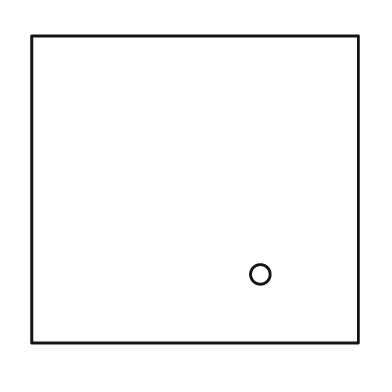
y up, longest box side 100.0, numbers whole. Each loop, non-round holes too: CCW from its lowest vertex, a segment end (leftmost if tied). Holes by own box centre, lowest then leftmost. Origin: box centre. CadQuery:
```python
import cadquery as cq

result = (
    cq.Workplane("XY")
    .moveTo(-50.0, -47.0)
    .lineTo(50.0, -47.0)
    .lineTo(50.0, 47.0)
    .lineTo(-50.0, 47.0)
    .close()
    .moveTo(20.0, -26.0)
    .circle(3.0)
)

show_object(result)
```